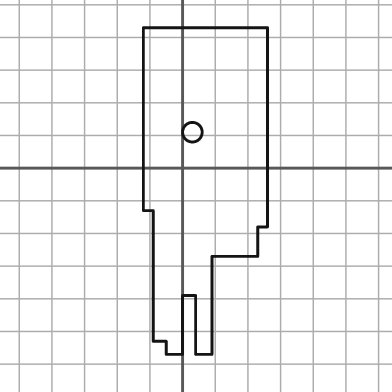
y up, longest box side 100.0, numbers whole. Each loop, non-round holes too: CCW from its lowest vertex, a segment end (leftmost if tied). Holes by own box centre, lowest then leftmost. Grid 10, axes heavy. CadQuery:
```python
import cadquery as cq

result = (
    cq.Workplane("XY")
    .moveTo(-5.0, -57.0)
    .lineTo(0.0, -57.0)
    .lineTo(0.0, -39.0)
    .lineTo(4.0, -39.0)
    .lineTo(4.0, -57.0)
    .lineTo(9.0, -57.0)
    .lineTo(9.0, -27.0)
    .lineTo(23.0, -27.0)
    .lineTo(23.0, -18.0)
    .lineTo(26.0, -18.0)
    .lineTo(26.0, 43.0)
    .lineTo(-12.0, 43.0)
    .lineTo(-12.0, -13.0)
    .lineTo(-9.0, -13.0)
    .lineTo(-9.0, -53.0)
    .lineTo(-5.0, -53.0)
    .close()
    .moveTo(3.0, 11.0)
    .circle(3.0)
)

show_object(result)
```